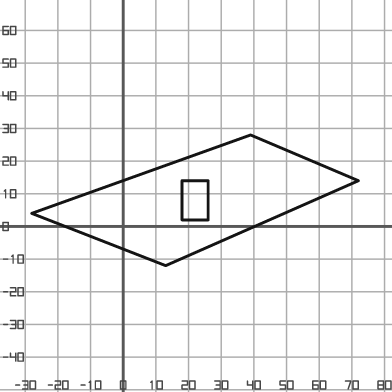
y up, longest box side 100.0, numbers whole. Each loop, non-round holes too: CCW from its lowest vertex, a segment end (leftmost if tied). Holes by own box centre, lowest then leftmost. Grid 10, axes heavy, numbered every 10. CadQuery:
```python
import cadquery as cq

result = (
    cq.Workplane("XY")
    .moveTo(13.0, -12.0)
    .lineTo(72.0, 14.0)
    .lineTo(39.0, 28.0)
    .lineTo(-28.0, 4.0)
    .close()
    .moveTo(18.0, 2.0)
    .lineTo(26.0, 2.0)
    .lineTo(26.0, 14.0)
    .lineTo(18.0, 14.0)
    .close()
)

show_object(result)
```